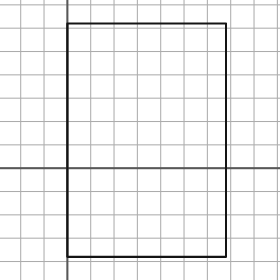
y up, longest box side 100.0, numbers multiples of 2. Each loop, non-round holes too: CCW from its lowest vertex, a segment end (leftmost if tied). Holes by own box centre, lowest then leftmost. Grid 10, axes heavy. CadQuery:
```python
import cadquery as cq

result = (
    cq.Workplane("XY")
    .moveTo(0.0, -38.0)
    .lineTo(68.0, -38.0)
    .lineTo(68.0, 62.0)
    .lineTo(0.0, 62.0)
    .close()
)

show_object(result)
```